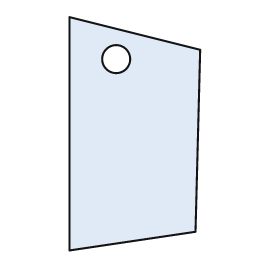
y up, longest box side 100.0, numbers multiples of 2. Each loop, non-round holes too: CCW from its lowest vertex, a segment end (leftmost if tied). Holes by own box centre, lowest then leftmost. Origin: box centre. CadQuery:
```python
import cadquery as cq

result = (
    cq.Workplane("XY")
    .moveTo(-28.0, -50.0)
    .lineTo(26.0, -42.0)
    .lineTo(28.0, 36.0)
    .lineTo(-28.0, 50.0)
    .close()
    .moveTo(-8.0, 32.0)
    .circle(6.0)
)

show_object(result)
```